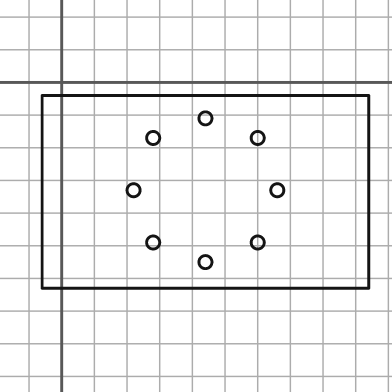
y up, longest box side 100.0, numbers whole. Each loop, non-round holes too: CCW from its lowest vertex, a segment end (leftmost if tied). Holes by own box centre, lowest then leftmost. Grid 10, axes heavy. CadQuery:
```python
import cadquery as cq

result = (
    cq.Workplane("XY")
    .moveTo(-6.0, -63.0)
    .lineTo(94.0, -63.0)
    .lineTo(94.0, -4.0)
    .lineTo(-6.0, -4.0)
    .close()
    .moveTo(44.0, -55.0)
    .circle(2.0)
    .moveTo(28.0, -49.0)
    .circle(2.0)
    .moveTo(60.0, -49.0)
    .circle(2.0)
    .moveTo(22.0, -33.0)
    .circle(2.0)
    .moveTo(66.0, -33.0)
    .circle(2.0)
    .moveTo(28.0, -17.0)
    .circle(2.0)
    .moveTo(60.0, -17.0)
    .circle(2.0)
    .moveTo(44.0, -11.0)
    .circle(2.0)
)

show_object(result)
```